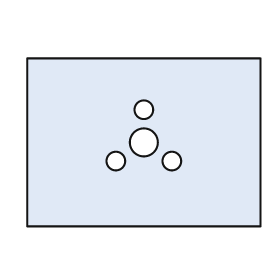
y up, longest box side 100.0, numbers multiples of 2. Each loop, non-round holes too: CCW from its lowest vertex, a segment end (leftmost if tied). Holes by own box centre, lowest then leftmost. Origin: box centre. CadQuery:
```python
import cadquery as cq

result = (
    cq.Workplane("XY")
    .moveTo(-50.0, -36.0)
    .lineTo(50.0, -36.0)
    .lineTo(50.0, 36.0)
    .lineTo(-50.0, 36.0)
    .close()
    .moveTo(-12.0, -8.0)
    .circle(4.0)
    .moveTo(12.0, -8.0)
    .circle(4.0)
    .moveTo(0.0, 0.0)
    .circle(6.0)
    .moveTo(0.0, 14.0)
    .circle(4.0)
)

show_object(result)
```